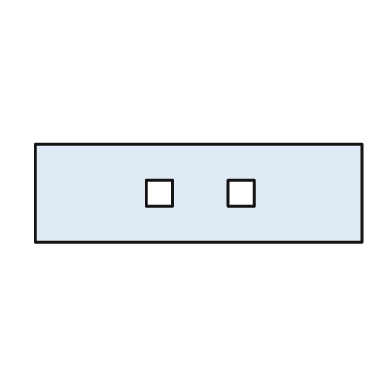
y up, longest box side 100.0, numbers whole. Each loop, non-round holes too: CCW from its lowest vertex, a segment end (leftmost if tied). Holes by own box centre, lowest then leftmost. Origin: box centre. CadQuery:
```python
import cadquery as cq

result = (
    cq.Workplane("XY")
    .moveTo(-50.0, -15.0)
    .lineTo(50.0, -15.0)
    .lineTo(50.0, 15.0)
    .lineTo(-50.0, 15.0)
    .close()
    .moveTo(-16.0, -4.0)
    .lineTo(-8.0, -4.0)
    .lineTo(-8.0, 4.0)
    .lineTo(-16.0, 4.0)
    .close()
    .moveTo(9.0, -4.0)
    .lineTo(17.0, -4.0)
    .lineTo(17.0, 4.0)
    .lineTo(9.0, 4.0)
    .close()
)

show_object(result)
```